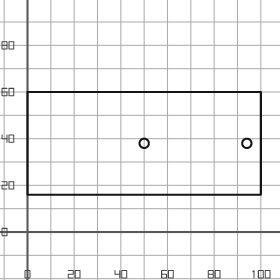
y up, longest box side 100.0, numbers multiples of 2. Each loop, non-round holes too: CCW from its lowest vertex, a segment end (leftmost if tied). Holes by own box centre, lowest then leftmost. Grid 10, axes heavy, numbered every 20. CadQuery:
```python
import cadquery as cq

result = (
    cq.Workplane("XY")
    .moveTo(0.0, 16.0)
    .lineTo(100.0, 16.0)
    .lineTo(100.0, 60.0)
    .lineTo(0.0, 60.0)
    .close()
    .moveTo(50.0, 38.0)
    .circle(2.0)
    .moveTo(94.0, 38.0)
    .circle(2.0)
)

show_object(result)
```